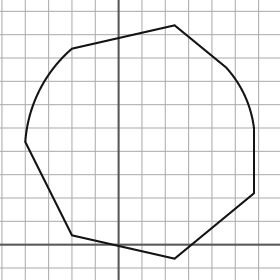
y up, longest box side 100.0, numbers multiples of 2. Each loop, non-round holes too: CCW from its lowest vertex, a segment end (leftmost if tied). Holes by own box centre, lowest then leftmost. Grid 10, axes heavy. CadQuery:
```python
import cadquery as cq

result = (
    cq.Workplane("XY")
    .moveTo(24.0, -6.0)
    .lineTo(58.0, 22.0)
    .lineTo(58.0, 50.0)
    .threePointArc((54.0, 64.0), (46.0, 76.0))
    .lineTo(24.0, 94.0)
    .lineTo(-20.0, 84.0)
    .threePointArc((-34.0, 66.0), (-40.0, 44.0))
    .lineTo(-20.0, 4.0)
    .close()
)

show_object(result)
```